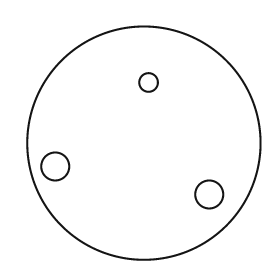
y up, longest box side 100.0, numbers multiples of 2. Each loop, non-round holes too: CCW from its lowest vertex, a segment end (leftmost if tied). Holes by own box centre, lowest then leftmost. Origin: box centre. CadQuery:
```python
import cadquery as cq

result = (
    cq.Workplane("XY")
    .moveTo(0.0, 0.0)
    .circle(50.0)
    .moveTo(28.0, -22.0)
    .circle(6.0)
    .moveTo(-38.0, -10.0)
    .circle(6.0)
    .moveTo(2.0, 26.0)
    .circle(4.0)
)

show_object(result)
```